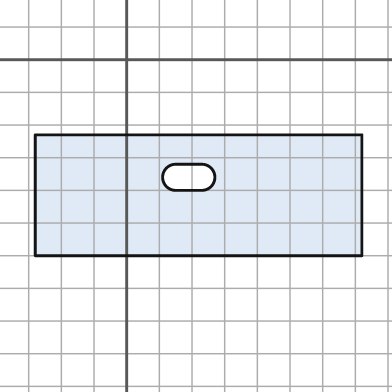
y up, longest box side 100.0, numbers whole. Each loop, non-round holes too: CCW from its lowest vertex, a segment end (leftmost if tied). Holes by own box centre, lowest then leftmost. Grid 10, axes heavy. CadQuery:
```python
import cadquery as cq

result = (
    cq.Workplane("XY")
    .moveTo(-28.0, -60.0)
    .lineTo(72.0, -60.0)
    .lineTo(72.0, -23.0)
    .lineTo(-28.0, -23.0)
    .close()
    .moveTo(15.0, -40.0)
    .lineTo(23.0, -40.0)
    .threePointArc((27.0, -36.0), (23.0, -32.0))
    .lineTo(15.0, -32.0)
    .threePointArc((11.0, -36.0), (15.0, -40.0))
    .close()
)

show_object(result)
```